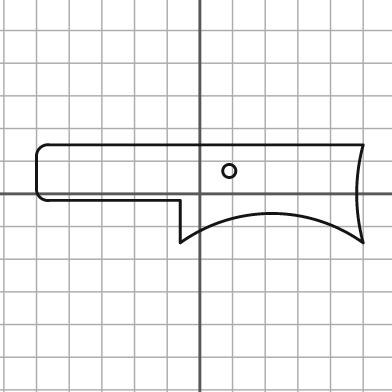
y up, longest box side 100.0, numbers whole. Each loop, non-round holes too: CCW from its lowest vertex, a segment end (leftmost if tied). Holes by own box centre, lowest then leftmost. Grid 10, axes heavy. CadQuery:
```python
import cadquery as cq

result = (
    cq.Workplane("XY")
    .moveTo(-6.0, -15.0)
    .threePointArc((22.0, -6.0), (50.0, -15.0))
    .threePointArc((48.0, 0.0), (50.0, 15.0))
    .lineTo(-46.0, 15.0)
    .threePointArc((-49.0, 14.0), (-50.0, 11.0))
    .lineTo(-50.0, 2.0)
    .threePointArc((-49.0, -1.0), (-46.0, -2.0))
    .lineTo(-6.0, -2.0)
    .close()
    .moveTo(9.0, 7.0)
    .circle(2.0)
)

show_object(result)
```